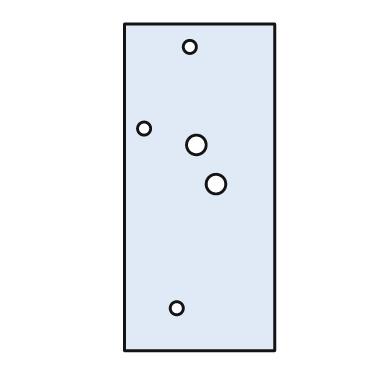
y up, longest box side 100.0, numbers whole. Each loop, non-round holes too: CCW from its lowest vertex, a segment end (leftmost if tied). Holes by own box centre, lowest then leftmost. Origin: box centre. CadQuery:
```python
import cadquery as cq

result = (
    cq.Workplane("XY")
    .moveTo(-23.0, -50.0)
    .lineTo(23.0, -50.0)
    .lineTo(23.0, 50.0)
    .lineTo(-23.0, 50.0)
    .close()
    .moveTo(-7.0, -37.0)
    .circle(2.0)
    .moveTo(5.0, 1.0)
    .circle(3.0)
    .moveTo(-1.0, 13.0)
    .circle(3.0)
    .moveTo(-17.0, 18.0)
    .circle(2.0)
    .moveTo(-3.0, 43.0)
    .circle(2.0)
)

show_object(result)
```